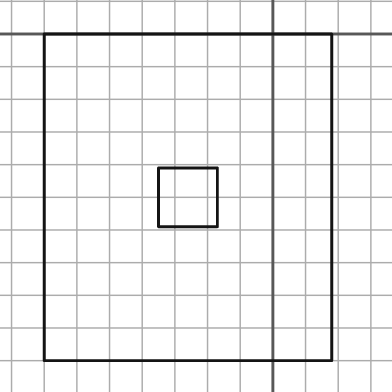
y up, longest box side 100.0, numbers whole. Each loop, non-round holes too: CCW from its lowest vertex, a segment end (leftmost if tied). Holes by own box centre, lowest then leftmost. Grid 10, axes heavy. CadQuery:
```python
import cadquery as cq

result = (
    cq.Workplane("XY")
    .moveTo(-70.0, -100.0)
    .lineTo(18.0, -100.0)
    .lineTo(18.0, 0.0)
    .lineTo(-70.0, 0.0)
    .close()
    .moveTo(-35.0, -59.0)
    .lineTo(-17.0, -59.0)
    .lineTo(-17.0, -41.0)
    .lineTo(-35.0, -41.0)
    .close()
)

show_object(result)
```